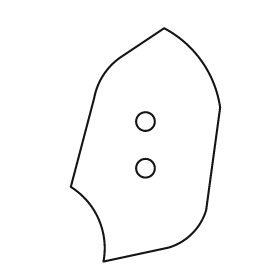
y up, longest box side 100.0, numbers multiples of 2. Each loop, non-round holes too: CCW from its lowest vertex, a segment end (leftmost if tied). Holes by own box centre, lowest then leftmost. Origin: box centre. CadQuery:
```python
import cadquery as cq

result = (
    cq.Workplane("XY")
    .moveTo(-18.0, -50.0)
    .lineTo(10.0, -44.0)
    .threePointArc((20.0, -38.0), (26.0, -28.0))
    .lineTo(32.0, 16.0)
    .threePointArc((24.0, 36.0), (8.0, 50.0))
    .lineTo(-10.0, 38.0)
    .threePointArc((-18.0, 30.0), (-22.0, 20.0))
    .lineTo(-32.0, -18.0)
    .threePointArc((-20.0, -32.0), (-18.0, -50.0))
    .close()
    .moveTo(0.0, -10.0)
    .circle(4.0)
    .moveTo(0.0, 10.0)
    .circle(4.0)
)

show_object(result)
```